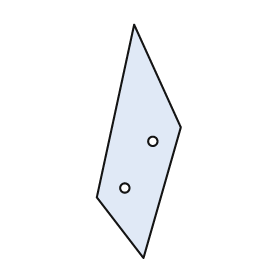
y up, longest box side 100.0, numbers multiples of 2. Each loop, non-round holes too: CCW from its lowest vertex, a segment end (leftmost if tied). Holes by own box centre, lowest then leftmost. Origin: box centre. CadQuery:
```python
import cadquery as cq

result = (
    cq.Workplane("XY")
    .moveTo(2.0, -50.0)
    .lineTo(18.0, 6.0)
    .lineTo(-2.0, 50.0)
    .lineTo(-18.0, -24.0)
    .close()
    .moveTo(-6.0, -20.0)
    .circle(2.0)
    .moveTo(6.0, 0.0)
    .circle(2.0)
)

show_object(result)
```